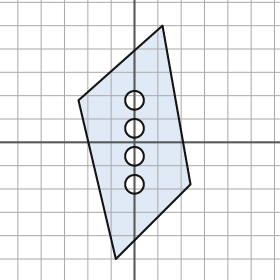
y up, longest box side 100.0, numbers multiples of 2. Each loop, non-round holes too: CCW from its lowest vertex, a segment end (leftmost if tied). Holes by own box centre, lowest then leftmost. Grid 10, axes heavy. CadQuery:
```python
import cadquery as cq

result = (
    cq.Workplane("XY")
    .moveTo(-8.0, -50.0)
    .lineTo(24.0, -18.0)
    .lineTo(12.0, 50.0)
    .lineTo(-24.0, 18.0)
    .close()
    .moveTo(0.0, -18.0)
    .circle(4.0)
    .moveTo(0.0, -6.0)
    .circle(4.0)
    .moveTo(0.0, 6.0)
    .circle(4.0)
    .moveTo(0.0, 18.0)
    .circle(4.0)
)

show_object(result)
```